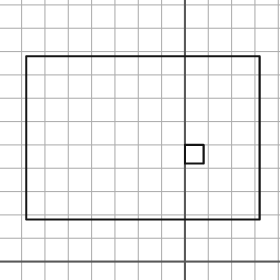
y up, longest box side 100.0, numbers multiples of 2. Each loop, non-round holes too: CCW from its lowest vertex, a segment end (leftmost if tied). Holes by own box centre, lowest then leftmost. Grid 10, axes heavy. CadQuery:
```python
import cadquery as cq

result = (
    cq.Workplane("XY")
    .moveTo(-68.0, 18.0)
    .lineTo(32.0, 18.0)
    .lineTo(32.0, 88.0)
    .lineTo(-68.0, 88.0)
    .close()
    .moveTo(0.0, 42.0)
    .lineTo(8.0, 42.0)
    .lineTo(8.0, 50.0)
    .lineTo(0.0, 50.0)
    .close()
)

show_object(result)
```